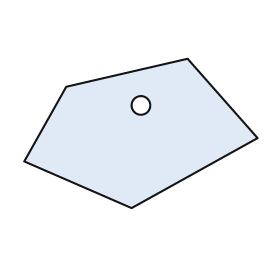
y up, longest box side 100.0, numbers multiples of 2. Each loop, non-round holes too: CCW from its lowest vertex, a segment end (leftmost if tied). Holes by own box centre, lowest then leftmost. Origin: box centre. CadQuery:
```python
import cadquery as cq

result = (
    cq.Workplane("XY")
    .moveTo(-4.0, -32.0)
    .lineTo(50.0, -2.0)
    .lineTo(20.0, 32.0)
    .lineTo(-32.0, 20.0)
    .lineTo(-50.0, -12.0)
    .close()
    .moveTo(0.0, 12.0)
    .circle(4.0)
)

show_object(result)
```